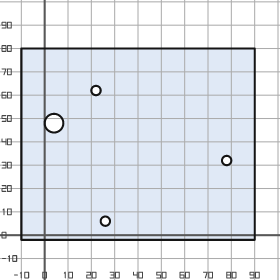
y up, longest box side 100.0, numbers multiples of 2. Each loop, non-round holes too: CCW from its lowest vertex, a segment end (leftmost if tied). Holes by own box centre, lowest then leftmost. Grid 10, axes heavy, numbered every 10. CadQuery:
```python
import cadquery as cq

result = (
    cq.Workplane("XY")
    .moveTo(-10.0, -2.0)
    .lineTo(90.0, -2.0)
    .lineTo(90.0, 80.0)
    .lineTo(-10.0, 80.0)
    .close()
    .moveTo(26.0, 6.0)
    .circle(2.0)
    .moveTo(78.0, 32.0)
    .circle(2.0)
    .moveTo(4.0, 48.0)
    .circle(4.0)
    .moveTo(22.0, 62.0)
    .circle(2.0)
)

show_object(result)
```